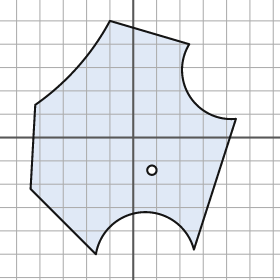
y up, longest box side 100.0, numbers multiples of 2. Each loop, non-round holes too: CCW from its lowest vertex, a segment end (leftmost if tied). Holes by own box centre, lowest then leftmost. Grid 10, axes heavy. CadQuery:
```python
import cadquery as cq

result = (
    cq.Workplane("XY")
    .moveTo(-16.0, -50.0)
    .threePointArc((4.0, -32.0), (26.0, -48.0))
    .lineTo(44.0, 8.0)
    .threePointArc((24.0, 18.0), (24.0, 40.0))
    .lineTo(-10.0, 50.0)
    .threePointArc((-24.0, 30.0), (-42.0, 14.0))
    .lineTo(-44.0, -22.0)
    .close()
    .moveTo(8.0, -14.0)
    .circle(2.0)
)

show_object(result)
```